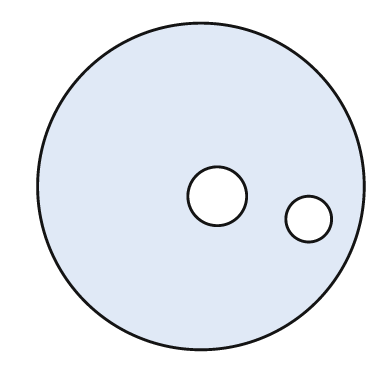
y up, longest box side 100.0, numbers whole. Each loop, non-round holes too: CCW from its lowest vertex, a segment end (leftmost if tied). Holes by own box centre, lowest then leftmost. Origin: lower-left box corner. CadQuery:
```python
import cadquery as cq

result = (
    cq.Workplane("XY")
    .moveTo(50.0, 50.0)
    .circle(50.0)
    .moveTo(83.0, 40.0)
    .circle(7.0)
    .moveTo(55.0, 47.0)
    .circle(9.0)
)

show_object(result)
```